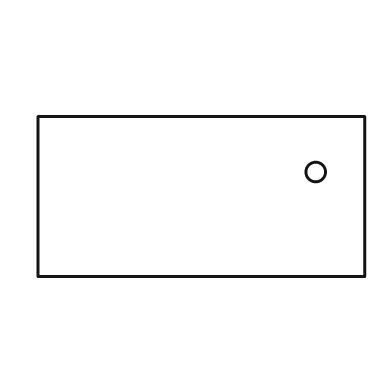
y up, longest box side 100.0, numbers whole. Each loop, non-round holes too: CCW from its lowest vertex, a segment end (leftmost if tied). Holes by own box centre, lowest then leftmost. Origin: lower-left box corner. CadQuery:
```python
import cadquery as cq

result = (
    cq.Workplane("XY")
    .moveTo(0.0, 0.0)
    .lineTo(100.0, 0.0)
    .lineTo(100.0, 49.0)
    .lineTo(0.0, 49.0)
    .close()
    .moveTo(85.0, 32.0)
    .circle(3.0)
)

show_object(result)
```